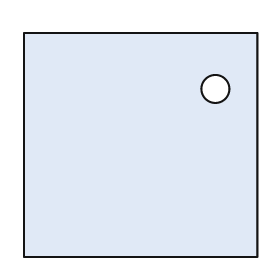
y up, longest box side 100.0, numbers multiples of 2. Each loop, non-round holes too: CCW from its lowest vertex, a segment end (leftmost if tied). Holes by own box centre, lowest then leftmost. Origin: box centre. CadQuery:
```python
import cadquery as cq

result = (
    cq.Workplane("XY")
    .moveTo(-50.0, -48.0)
    .lineTo(50.0, -48.0)
    .lineTo(50.0, 48.0)
    .lineTo(-50.0, 48.0)
    .close()
    .moveTo(32.0, 24.0)
    .circle(6.0)
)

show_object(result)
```